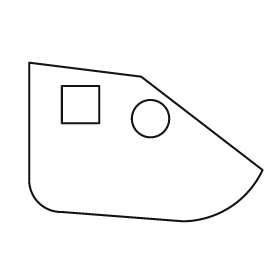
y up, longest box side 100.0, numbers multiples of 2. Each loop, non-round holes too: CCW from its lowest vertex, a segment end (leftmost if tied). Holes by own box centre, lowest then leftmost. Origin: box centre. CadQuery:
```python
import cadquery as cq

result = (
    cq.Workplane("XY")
    .moveTo(16.0, -34.0)
    .threePointArc((36.0, -28.0), (50.0, -12.0))
    .lineTo(-2.0, 28.0)
    .lineTo(-50.0, 34.0)
    .lineTo(-50.0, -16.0)
    .threePointArc((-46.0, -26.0), (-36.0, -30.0))
    .close()
    .moveTo(2.0, 10.0)
    .circle(8.0)
    .moveTo(-36.0, 8.0)
    .lineTo(-20.0, 8.0)
    .lineTo(-20.0, 24.0)
    .lineTo(-36.0, 24.0)
    .close()
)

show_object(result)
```